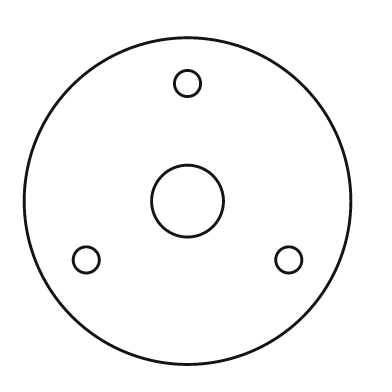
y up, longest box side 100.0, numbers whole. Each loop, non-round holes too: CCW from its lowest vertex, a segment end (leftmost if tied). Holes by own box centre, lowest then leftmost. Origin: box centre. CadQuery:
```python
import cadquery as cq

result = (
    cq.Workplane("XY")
    .moveTo(0.0, 0.0)
    .circle(50.0)
    .moveTo(-31.0, -18.0)
    .circle(4.0)
    .moveTo(31.0, -18.0)
    .circle(4.0)
    .moveTo(0.0, 0.0)
    .circle(11.0)
    .moveTo(0.0, 36.0)
    .circle(4.0)
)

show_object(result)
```